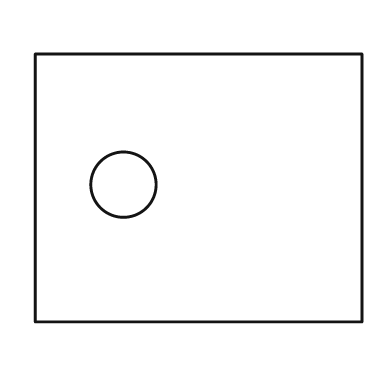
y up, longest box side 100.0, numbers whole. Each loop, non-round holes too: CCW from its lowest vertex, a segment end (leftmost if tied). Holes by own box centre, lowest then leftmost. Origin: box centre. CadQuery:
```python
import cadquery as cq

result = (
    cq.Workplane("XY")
    .moveTo(-50.0, -41.0)
    .lineTo(50.0, -41.0)
    .lineTo(50.0, 41.0)
    .lineTo(-50.0, 41.0)
    .close()
    .moveTo(-23.0, 1.0)
    .circle(10.0)
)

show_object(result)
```